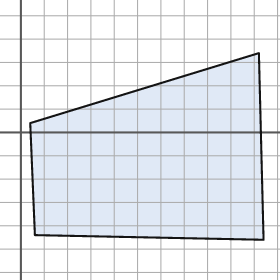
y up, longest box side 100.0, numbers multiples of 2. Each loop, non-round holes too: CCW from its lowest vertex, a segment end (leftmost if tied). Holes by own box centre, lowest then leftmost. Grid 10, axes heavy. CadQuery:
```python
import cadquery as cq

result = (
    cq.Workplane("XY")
    .moveTo(104.0, -46.0)
    .lineTo(102.0, 34.0)
    .lineTo(4.0, 4.0)
    .lineTo(6.0, -44.0)
    .close()
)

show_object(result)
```